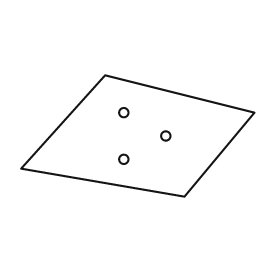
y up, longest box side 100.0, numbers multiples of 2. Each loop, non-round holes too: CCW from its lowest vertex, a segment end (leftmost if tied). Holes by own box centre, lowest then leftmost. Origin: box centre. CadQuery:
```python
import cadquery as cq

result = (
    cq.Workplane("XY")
    .moveTo(20.0, -26.0)
    .lineTo(50.0, 10.0)
    .lineTo(-14.0, 26.0)
    .lineTo(-50.0, -14.0)
    .close()
    .moveTo(-6.0, -10.0)
    .circle(2.0)
    .moveTo(12.0, 0.0)
    .circle(2.0)
    .moveTo(-6.0, 10.0)
    .circle(2.0)
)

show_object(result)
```